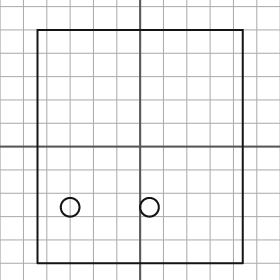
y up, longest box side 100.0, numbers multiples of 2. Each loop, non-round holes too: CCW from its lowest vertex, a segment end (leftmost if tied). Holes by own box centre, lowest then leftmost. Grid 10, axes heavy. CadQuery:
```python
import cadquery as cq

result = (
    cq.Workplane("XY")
    .moveTo(-44.0, -50.0)
    .lineTo(44.0, -50.0)
    .lineTo(44.0, 50.0)
    .lineTo(-44.0, 50.0)
    .close()
    .moveTo(-30.0, -26.0)
    .circle(4.0)
    .moveTo(4.0, -26.0)
    .circle(4.0)
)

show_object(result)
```